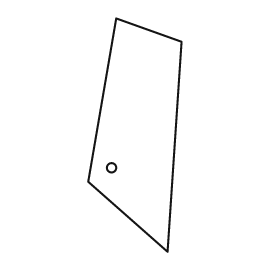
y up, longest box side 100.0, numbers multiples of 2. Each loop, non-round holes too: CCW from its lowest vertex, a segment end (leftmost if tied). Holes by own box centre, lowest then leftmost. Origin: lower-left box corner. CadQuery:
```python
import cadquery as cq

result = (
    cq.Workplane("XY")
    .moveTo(34.0, 0.0)
    .lineTo(40.0, 90.0)
    .lineTo(12.0, 100.0)
    .lineTo(0.0, 30.0)
    .close()
    .moveTo(10.0, 36.0)
    .circle(2.0)
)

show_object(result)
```